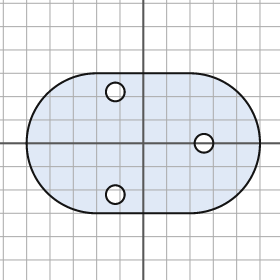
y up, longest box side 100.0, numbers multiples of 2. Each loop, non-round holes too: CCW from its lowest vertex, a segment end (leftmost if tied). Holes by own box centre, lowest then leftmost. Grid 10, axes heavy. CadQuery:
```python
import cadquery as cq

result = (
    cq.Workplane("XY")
    .moveTo(-20.0, -30.0)
    .lineTo(20.0, -30.0)
    .threePointArc((50.0, 0.0), (20.0, 30.0))
    .lineTo(-20.0, 30.0)
    .threePointArc((-50.0, 0.0), (-20.0, -30.0))
    .close()
    .moveTo(-12.0, -22.0)
    .circle(4.0)
    .moveTo(26.0, 0.0)
    .circle(4.0)
    .moveTo(-12.0, 22.0)
    .circle(4.0)
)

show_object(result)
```